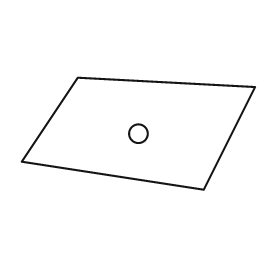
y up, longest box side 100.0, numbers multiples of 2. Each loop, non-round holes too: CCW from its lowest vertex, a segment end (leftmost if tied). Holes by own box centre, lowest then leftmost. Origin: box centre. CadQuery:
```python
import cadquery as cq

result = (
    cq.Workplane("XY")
    .moveTo(28.0, -24.0)
    .lineTo(50.0, 20.0)
    .lineTo(-26.0, 24.0)
    .lineTo(-50.0, -12.0)
    .close()
    .moveTo(0.0, 0.0)
    .circle(4.0)
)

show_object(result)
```